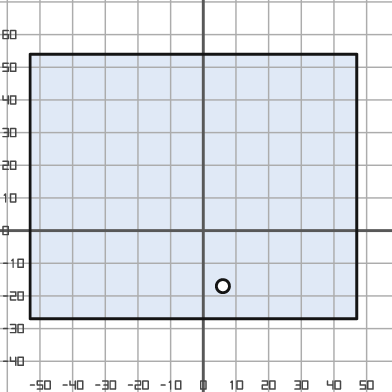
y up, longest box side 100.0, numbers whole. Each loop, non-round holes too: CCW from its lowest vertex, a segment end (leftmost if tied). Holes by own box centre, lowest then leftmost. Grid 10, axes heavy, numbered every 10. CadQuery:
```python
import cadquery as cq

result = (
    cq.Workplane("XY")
    .moveTo(-53.0, -27.0)
    .lineTo(47.0, -27.0)
    .lineTo(47.0, 54.0)
    .lineTo(-53.0, 54.0)
    .close()
    .moveTo(6.0, -17.0)
    .circle(2.0)
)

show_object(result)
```